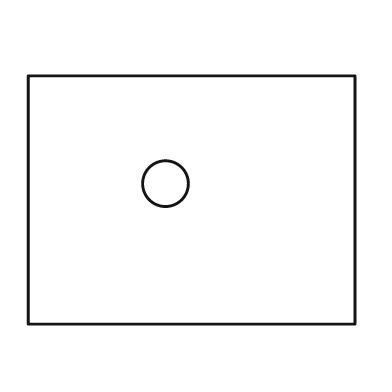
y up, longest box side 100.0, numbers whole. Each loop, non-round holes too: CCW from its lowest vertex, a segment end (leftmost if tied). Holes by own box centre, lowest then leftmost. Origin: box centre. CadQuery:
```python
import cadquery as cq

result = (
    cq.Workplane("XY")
    .moveTo(-50.0, -38.0)
    .lineTo(50.0, -38.0)
    .lineTo(50.0, 38.0)
    .lineTo(-50.0, 38.0)
    .close()
    .moveTo(-8.0, 5.0)
    .circle(7.0)
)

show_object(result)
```